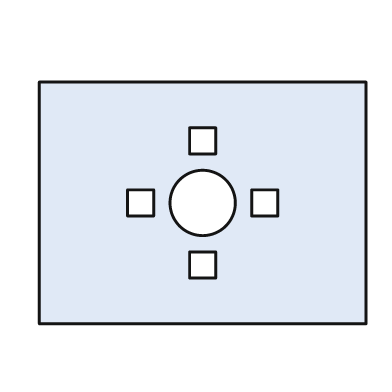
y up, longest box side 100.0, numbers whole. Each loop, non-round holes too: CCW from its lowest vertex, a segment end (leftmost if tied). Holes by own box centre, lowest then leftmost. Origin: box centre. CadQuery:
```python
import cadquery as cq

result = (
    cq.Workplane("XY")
    .moveTo(-50.0, -37.0)
    .lineTo(50.0, -37.0)
    .lineTo(50.0, 37.0)
    .lineTo(-50.0, 37.0)
    .close()
    .moveTo(-4.0, -23.0)
    .lineTo(4.0, -23.0)
    .lineTo(4.0, -15.0)
    .lineTo(-4.0, -15.0)
    .close()
    .moveTo(-23.0, -4.0)
    .lineTo(-15.0, -4.0)
    .lineTo(-15.0, 4.0)
    .lineTo(-23.0, 4.0)
    .close()
    .moveTo(0.0, 0.0)
    .circle(10.0)
    .moveTo(15.0, -4.0)
    .lineTo(23.0, -4.0)
    .lineTo(23.0, 4.0)
    .lineTo(15.0, 4.0)
    .close()
    .moveTo(-4.0, 15.0)
    .lineTo(4.0, 15.0)
    .lineTo(4.0, 23.0)
    .lineTo(-4.0, 23.0)
    .close()
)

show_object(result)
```